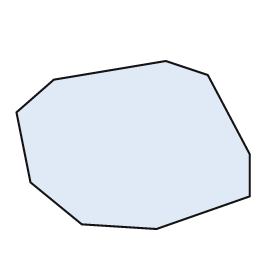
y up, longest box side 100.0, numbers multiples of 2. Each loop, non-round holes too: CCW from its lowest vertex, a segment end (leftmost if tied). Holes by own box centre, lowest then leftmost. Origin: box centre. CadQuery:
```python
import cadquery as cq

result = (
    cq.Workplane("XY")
    .moveTo(10.0, -36.0)
    .lineTo(50.0, -22.0)
    .lineTo(50.0, -4.0)
    .lineTo(32.0, 30.0)
    .lineTo(14.0, 36.0)
    .lineTo(-34.0, 28.0)
    .lineTo(-50.0, 14.0)
    .lineTo(-44.0, -16.0)
    .lineTo(-22.0, -34.0)
    .close()
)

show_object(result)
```